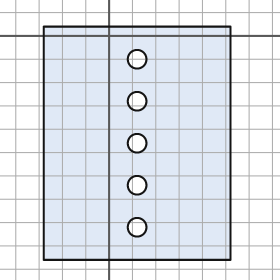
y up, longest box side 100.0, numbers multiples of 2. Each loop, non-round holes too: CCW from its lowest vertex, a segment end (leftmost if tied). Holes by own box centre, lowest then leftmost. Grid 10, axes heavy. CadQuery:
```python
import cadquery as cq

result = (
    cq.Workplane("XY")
    .moveTo(-28.0, -96.0)
    .lineTo(52.0, -96.0)
    .lineTo(52.0, 4.0)
    .lineTo(-28.0, 4.0)
    .close()
    .moveTo(12.0, -82.0)
    .circle(4.0)
    .moveTo(12.0, -64.0)
    .circle(4.0)
    .moveTo(12.0, -46.0)
    .circle(4.0)
    .moveTo(12.0, -28.0)
    .circle(4.0)
    .moveTo(12.0, -10.0)
    .circle(4.0)
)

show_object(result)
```